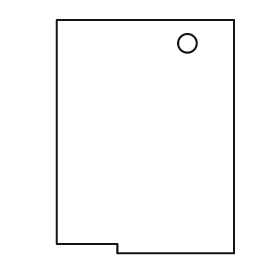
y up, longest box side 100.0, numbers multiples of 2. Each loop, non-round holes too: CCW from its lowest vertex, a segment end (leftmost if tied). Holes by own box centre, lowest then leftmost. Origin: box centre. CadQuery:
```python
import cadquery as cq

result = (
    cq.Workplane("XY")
    .moveTo(-12.0, -50.0)
    .lineTo(38.0, -50.0)
    .lineTo(38.0, 50.0)
    .lineTo(-38.0, 50.0)
    .lineTo(-38.0, -46.0)
    .lineTo(-12.0, -46.0)
    .close()
    .moveTo(18.0, 40.0)
    .circle(4.0)
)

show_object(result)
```